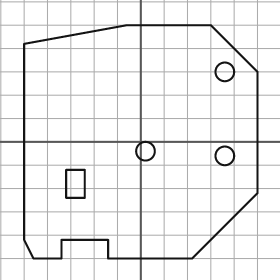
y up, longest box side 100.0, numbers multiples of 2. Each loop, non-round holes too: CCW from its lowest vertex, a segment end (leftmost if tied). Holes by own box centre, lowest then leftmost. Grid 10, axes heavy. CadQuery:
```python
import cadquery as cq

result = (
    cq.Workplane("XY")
    .moveTo(-46.0, -50.0)
    .lineTo(-34.0, -50.0)
    .lineTo(-34.0, -42.0)
    .lineTo(-14.0, -42.0)
    .lineTo(-14.0, -50.0)
    .lineTo(22.0, -50.0)
    .lineTo(50.0, -22.0)
    .lineTo(50.0, 30.0)
    .lineTo(30.0, 50.0)
    .lineTo(-6.0, 50.0)
    .lineTo(-50.0, 42.0)
    .lineTo(-50.0, -42.0)
    .close()
    .moveTo(-32.0, -24.0)
    .lineTo(-24.0, -24.0)
    .lineTo(-24.0, -12.0)
    .lineTo(-32.0, -12.0)
    .close()
    .moveTo(36.0, -6.0)
    .circle(4.0)
    .moveTo(2.0, -4.0)
    .circle(4.0)
    .moveTo(36.0, 30.0)
    .circle(4.0)
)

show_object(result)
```